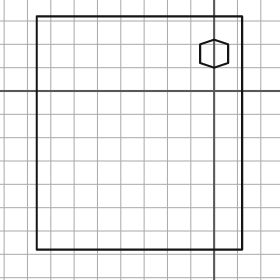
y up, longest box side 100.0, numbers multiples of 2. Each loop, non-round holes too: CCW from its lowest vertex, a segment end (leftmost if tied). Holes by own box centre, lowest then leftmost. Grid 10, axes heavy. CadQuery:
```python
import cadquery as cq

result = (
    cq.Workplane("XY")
    .moveTo(-76.0, -68.0)
    .lineTo(12.0, -68.0)
    .lineTo(12.0, 32.0)
    .lineTo(-76.0, 32.0)
    .close()
    .moveTo(0.0, 10.0)
    .lineTo(6.0, 12.0)
    .lineTo(6.0, 20.0)
    .lineTo(0.0, 22.0)
    .lineTo(-6.0, 20.0)
    .lineTo(-6.0, 12.0)
    .close()
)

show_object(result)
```